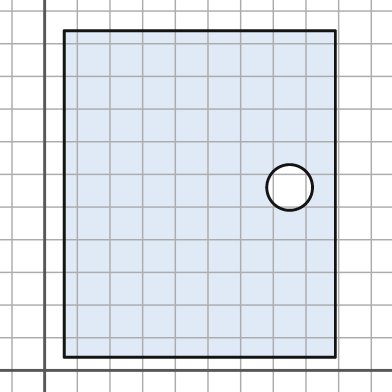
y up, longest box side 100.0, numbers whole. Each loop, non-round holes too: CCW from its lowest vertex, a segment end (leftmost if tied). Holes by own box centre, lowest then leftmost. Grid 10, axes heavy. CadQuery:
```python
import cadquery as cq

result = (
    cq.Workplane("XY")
    .moveTo(6.0, 4.0)
    .lineTo(89.0, 4.0)
    .lineTo(89.0, 104.0)
    .lineTo(6.0, 104.0)
    .close()
    .moveTo(75.0, 56.0)
    .circle(7.0)
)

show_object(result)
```